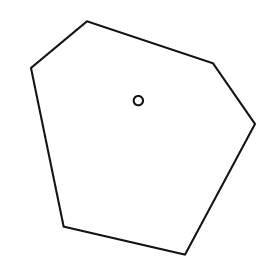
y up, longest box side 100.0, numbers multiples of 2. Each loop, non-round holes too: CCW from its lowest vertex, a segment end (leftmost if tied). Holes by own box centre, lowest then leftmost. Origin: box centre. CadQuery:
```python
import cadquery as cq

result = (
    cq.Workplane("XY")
    .moveTo(18.0, -50.0)
    .lineTo(48.0, 6.0)
    .lineTo(30.0, 32.0)
    .lineTo(-24.0, 50.0)
    .lineTo(-48.0, 30.0)
    .lineTo(-34.0, -38.0)
    .close()
    .moveTo(-2.0, 16.0)
    .circle(2.0)
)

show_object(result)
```